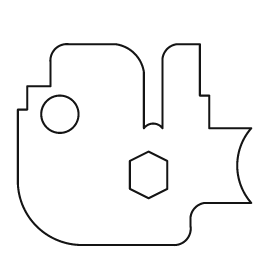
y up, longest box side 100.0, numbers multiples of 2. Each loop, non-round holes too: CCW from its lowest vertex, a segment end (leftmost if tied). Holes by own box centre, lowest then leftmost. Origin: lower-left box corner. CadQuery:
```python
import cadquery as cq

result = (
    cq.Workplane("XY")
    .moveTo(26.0, 0.0)
    .lineTo(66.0, 0.0)
    .threePointArc((72.0, 2.0), (74.0, 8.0))
    .lineTo(74.0, 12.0)
    .threePointArc((76.0, 16.0), (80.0, 18.0))
    .lineTo(100.0, 18.0)
    .threePointArc((94.0, 34.0), (100.0, 50.0))
    .lineTo(82.0, 50.0)
    .lineTo(82.0, 64.0)
    .lineTo(78.0, 64.0)
    .lineTo(78.0, 86.0)
    .lineTo(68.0, 86.0)
    .threePointArc((64.0, 84.0), (62.0, 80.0))
    .lineTo(62.0, 50.0)
    .threePointArc((58.0, 52.0), (54.0, 50.0))
    .lineTo(54.0, 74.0)
    .threePointArc((50.0, 82.0), (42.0, 86.0))
    .lineTo(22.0, 86.0)
    .threePointArc((16.0, 84.0), (14.0, 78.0))
    .lineTo(14.0, 68.0)
    .lineTo(4.0, 68.0)
    .lineTo(4.0, 58.0)
    .lineTo(0.0, 58.0)
    .lineTo(0.0, 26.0)
    .threePointArc((8.0, 8.0), (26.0, 0.0))
    .close()
    .moveTo(56.0, 20.0)
    .lineTo(64.0, 24.0)
    .lineTo(64.0, 36.0)
    .lineTo(56.0, 40.0)
    .lineTo(48.0, 36.0)
    .lineTo(48.0, 24.0)
    .close()
    .moveTo(18.0, 56.0)
    .circle(8.0)
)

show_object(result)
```